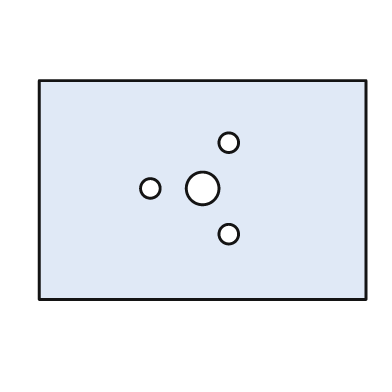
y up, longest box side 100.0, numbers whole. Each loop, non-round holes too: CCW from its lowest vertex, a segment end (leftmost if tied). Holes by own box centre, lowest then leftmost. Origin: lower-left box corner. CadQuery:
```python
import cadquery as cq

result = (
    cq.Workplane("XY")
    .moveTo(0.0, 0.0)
    .lineTo(100.0, 0.0)
    .lineTo(100.0, 67.0)
    .lineTo(0.0, 67.0)
    .close()
    .moveTo(58.0, 20.0)
    .circle(3.0)
    .moveTo(34.0, 34.0)
    .circle(3.0)
    .moveTo(50.0, 34.0)
    .circle(5.0)
    .moveTo(58.0, 48.0)
    .circle(3.0)
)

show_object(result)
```